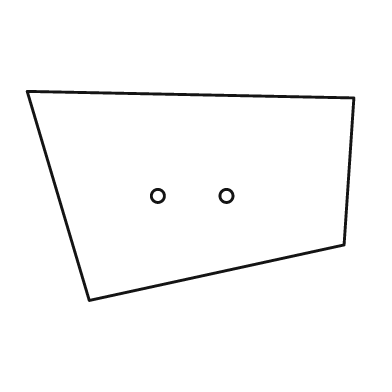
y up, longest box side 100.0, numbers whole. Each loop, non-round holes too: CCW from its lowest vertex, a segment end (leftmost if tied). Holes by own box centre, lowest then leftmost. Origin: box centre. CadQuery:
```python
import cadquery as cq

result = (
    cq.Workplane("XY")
    .moveTo(-31.0, -32.0)
    .lineTo(47.0, -15.0)
    .lineTo(50.0, 30.0)
    .lineTo(-50.0, 32.0)
    .close()
    .moveTo(-10.0, 0.0)
    .circle(2.0)
    .moveTo(11.0, 0.0)
    .circle(2.0)
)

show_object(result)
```